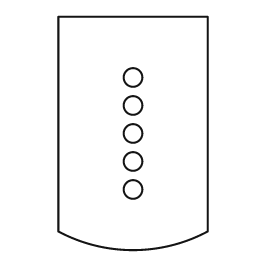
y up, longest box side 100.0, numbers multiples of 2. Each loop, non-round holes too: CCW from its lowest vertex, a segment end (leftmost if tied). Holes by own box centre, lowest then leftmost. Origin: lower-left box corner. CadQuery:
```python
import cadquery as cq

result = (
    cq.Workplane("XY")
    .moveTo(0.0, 8.0)
    .threePointArc((32.0, 0.0), (64.0, 8.0))
    .lineTo(64.0, 100.0)
    .lineTo(0.0, 100.0)
    .close()
    .moveTo(32.0, 26.0)
    .circle(4.0)
    .moveTo(32.0, 38.0)
    .circle(4.0)
    .moveTo(32.0, 50.0)
    .circle(4.0)
    .moveTo(32.0, 62.0)
    .circle(4.0)
    .moveTo(32.0, 74.0)
    .circle(4.0)
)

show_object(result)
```